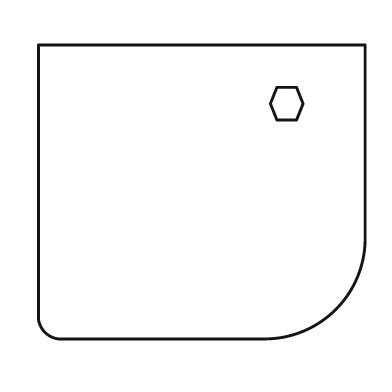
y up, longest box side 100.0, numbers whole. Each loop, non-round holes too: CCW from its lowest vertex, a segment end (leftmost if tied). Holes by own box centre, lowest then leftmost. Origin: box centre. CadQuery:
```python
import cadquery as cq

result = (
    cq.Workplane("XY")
    .moveTo(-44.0, -45.0)
    .lineTo(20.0, -45.0)
    .threePointArc((41.0, -36.0), (50.0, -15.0))
    .lineTo(50.0, 45.0)
    .lineTo(-50.0, 45.0)
    .lineTo(-50.0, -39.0)
    .threePointArc((-48.0, -43.0), (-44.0, -45.0))
    .close()
    .moveTo(23.0, 22.0)
    .lineTo(29.0, 22.0)
    .lineTo(31.0, 27.0)
    .lineTo(29.0, 32.0)
    .lineTo(23.0, 32.0)
    .lineTo(21.0, 27.0)
    .close()
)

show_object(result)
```